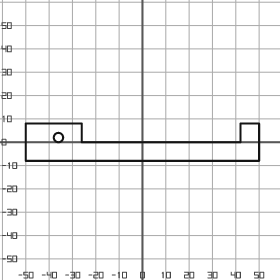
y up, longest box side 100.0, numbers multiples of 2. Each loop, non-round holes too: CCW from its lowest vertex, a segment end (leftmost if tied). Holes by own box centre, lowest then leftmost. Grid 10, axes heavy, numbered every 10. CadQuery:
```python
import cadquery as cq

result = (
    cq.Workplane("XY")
    .moveTo(-50.0, -8.0)
    .lineTo(50.0, -8.0)
    .lineTo(50.0, 8.0)
    .lineTo(42.0, 8.0)
    .lineTo(42.0, 0.0)
    .lineTo(-26.0, 0.0)
    .lineTo(-26.0, 8.0)
    .lineTo(-50.0, 8.0)
    .close()
    .moveTo(-36.0, 2.0)
    .circle(2.0)
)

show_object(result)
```